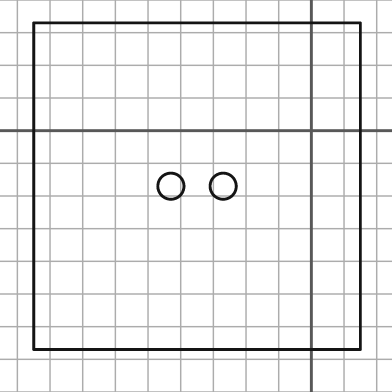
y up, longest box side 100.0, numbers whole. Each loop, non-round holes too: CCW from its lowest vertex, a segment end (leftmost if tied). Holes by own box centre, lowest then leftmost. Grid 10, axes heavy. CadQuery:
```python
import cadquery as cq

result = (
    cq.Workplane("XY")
    .moveTo(-85.0, -67.0)
    .lineTo(15.0, -67.0)
    .lineTo(15.0, 33.0)
    .lineTo(-85.0, 33.0)
    .close()
    .moveTo(-43.0, -17.0)
    .circle(4.0)
    .moveTo(-27.0, -17.0)
    .circle(4.0)
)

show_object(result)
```